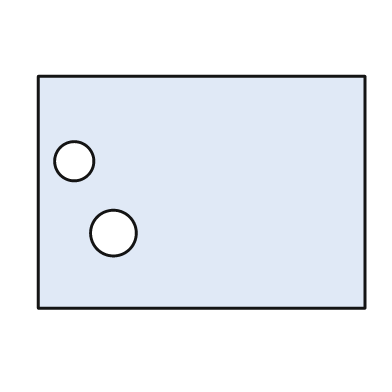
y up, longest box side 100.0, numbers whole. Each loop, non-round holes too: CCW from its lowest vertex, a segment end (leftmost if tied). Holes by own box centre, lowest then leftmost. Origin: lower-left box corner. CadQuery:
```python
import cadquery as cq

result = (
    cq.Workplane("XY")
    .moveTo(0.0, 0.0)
    .lineTo(100.0, 0.0)
    .lineTo(100.0, 71.0)
    .lineTo(0.0, 71.0)
    .close()
    .moveTo(23.0, 23.0)
    .circle(7.0)
    .moveTo(11.0, 45.0)
    .circle(6.0)
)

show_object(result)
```